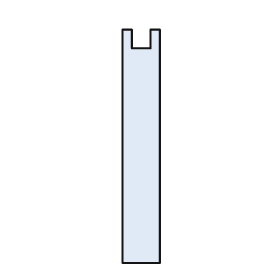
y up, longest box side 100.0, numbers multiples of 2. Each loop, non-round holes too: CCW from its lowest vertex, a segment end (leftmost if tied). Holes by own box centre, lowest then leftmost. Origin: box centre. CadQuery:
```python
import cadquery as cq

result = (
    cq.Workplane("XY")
    .moveTo(-8.0, -50.0)
    .lineTo(8.0, -50.0)
    .lineTo(8.0, 50.0)
    .lineTo(4.0, 50.0)
    .lineTo(4.0, 42.0)
    .lineTo(-4.0, 42.0)
    .lineTo(-4.0, 50.0)
    .lineTo(-8.0, 50.0)
    .close()
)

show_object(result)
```